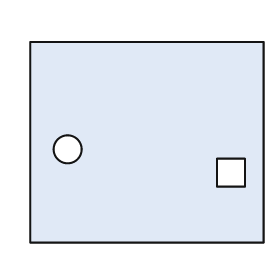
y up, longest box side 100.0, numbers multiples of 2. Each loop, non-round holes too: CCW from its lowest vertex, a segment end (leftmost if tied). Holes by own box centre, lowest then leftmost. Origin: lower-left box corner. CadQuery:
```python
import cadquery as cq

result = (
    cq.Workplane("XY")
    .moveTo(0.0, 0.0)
    .lineTo(100.0, 0.0)
    .lineTo(100.0, 86.0)
    .lineTo(0.0, 86.0)
    .close()
    .moveTo(80.0, 24.0)
    .lineTo(92.0, 24.0)
    .lineTo(92.0, 36.0)
    .lineTo(80.0, 36.0)
    .close()
    .moveTo(16.0, 40.0)
    .circle(6.0)
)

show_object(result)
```